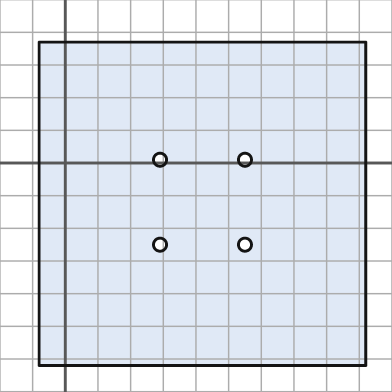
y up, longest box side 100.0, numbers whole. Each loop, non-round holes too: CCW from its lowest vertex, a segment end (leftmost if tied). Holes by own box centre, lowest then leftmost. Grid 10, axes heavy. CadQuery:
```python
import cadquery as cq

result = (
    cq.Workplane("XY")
    .moveTo(-8.0, -62.0)
    .lineTo(92.0, -62.0)
    .lineTo(92.0, 37.0)
    .lineTo(-8.0, 37.0)
    .close()
    .moveTo(29.0, -25.0)
    .circle(2.0)
    .moveTo(55.0, -25.0)
    .circle(2.0)
    .moveTo(29.0, 1.0)
    .circle(2.0)
    .moveTo(55.0, 1.0)
    .circle(2.0)
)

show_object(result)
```